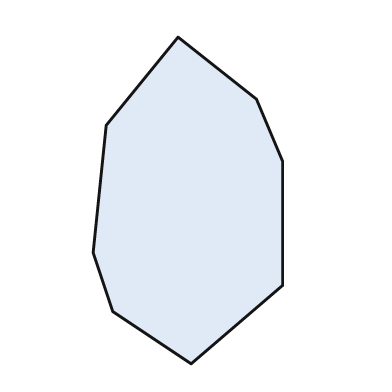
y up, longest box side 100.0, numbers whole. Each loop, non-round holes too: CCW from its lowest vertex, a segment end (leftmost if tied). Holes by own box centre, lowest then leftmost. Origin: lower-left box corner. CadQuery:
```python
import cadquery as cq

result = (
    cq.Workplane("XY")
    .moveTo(30.0, 0.0)
    .lineTo(58.0, 24.0)
    .lineTo(58.0, 62.0)
    .lineTo(50.0, 81.0)
    .lineTo(26.0, 100.0)
    .lineTo(4.0, 73.0)
    .lineTo(0.0, 34.0)
    .lineTo(6.0, 16.0)
    .close()
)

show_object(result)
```